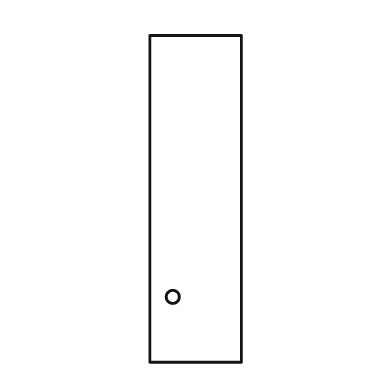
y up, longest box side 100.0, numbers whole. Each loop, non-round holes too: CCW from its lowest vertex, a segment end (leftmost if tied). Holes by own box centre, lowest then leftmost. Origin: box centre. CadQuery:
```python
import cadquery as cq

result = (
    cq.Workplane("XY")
    .moveTo(-14.0, -50.0)
    .lineTo(14.0, -50.0)
    .lineTo(14.0, 50.0)
    .lineTo(-14.0, 50.0)
    .close()
    .moveTo(-7.0, -30.0)
    .circle(2.0)
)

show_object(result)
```